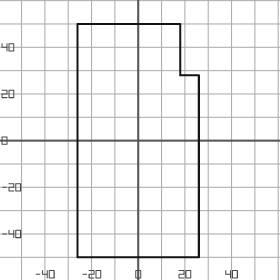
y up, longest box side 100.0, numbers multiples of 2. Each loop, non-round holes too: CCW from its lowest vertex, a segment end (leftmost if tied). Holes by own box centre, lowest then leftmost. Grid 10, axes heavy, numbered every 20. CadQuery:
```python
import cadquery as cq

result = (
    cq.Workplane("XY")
    .moveTo(-26.0, -50.0)
    .lineTo(26.0, -50.0)
    .lineTo(26.0, 28.0)
    .lineTo(18.0, 28.0)
    .lineTo(18.0, 50.0)
    .lineTo(-26.0, 50.0)
    .close()
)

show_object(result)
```